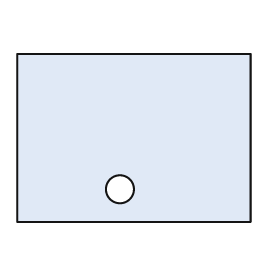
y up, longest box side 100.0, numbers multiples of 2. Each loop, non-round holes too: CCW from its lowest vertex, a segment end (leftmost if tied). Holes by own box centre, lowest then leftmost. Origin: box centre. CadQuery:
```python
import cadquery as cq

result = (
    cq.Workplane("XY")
    .moveTo(-50.0, -36.0)
    .lineTo(50.0, -36.0)
    .lineTo(50.0, 36.0)
    .lineTo(-50.0, 36.0)
    .close()
    .moveTo(-6.0, -22.0)
    .circle(6.0)
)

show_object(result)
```